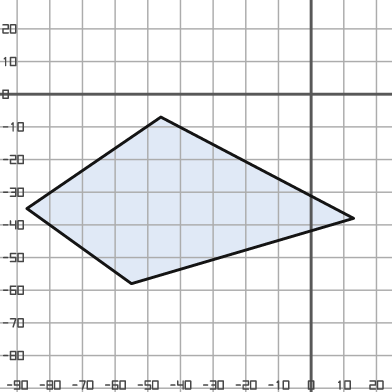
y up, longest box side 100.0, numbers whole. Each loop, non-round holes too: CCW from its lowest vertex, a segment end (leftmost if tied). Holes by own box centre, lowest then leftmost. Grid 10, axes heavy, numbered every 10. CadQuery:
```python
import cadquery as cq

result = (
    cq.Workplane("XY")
    .moveTo(-55.0, -58.0)
    .lineTo(13.0, -38.0)
    .lineTo(-46.0, -7.0)
    .lineTo(-87.0, -35.0)
    .close()
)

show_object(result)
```